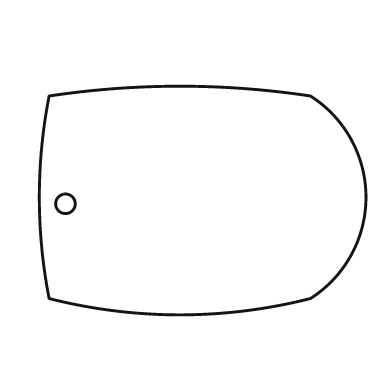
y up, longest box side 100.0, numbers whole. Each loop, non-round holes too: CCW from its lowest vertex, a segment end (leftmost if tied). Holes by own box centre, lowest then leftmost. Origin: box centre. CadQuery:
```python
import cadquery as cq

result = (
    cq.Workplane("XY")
    .moveTo(-47.0, -30.0)
    .threePointArc((-7.0, -35.0), (33.0, -30.0))
    .threePointArc((50.0, 1.0), (33.0, 32.0))
    .threePointArc((-7.0, 35.0), (-47.0, 32.0))
    .threePointArc((-50.0, 1.0), (-47.0, -30.0))
    .close()
    .moveTo(-42.0, -1.0)
    .circle(3.0)
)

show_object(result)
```